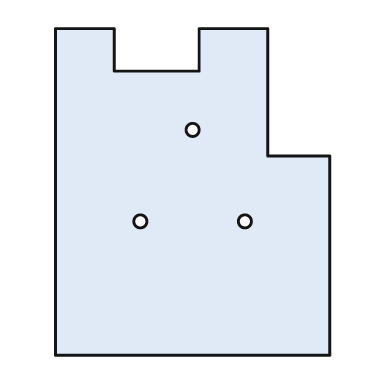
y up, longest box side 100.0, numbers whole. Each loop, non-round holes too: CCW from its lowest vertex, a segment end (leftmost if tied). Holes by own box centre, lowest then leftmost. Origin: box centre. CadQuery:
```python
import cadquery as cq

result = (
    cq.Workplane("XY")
    .moveTo(-42.0, -50.0)
    .lineTo(42.0, -50.0)
    .lineTo(42.0, 11.0)
    .lineTo(23.0, 11.0)
    .lineTo(23.0, 50.0)
    .lineTo(2.0, 50.0)
    .lineTo(2.0, 37.0)
    .lineTo(-24.0, 37.0)
    .lineTo(-24.0, 50.0)
    .lineTo(-42.0, 50.0)
    .close()
    .moveTo(-16.0, -9.0)
    .circle(2.0)
    .moveTo(16.0, -9.0)
    .circle(2.0)
    .moveTo(0.0, 19.0)
    .circle(2.0)
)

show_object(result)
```